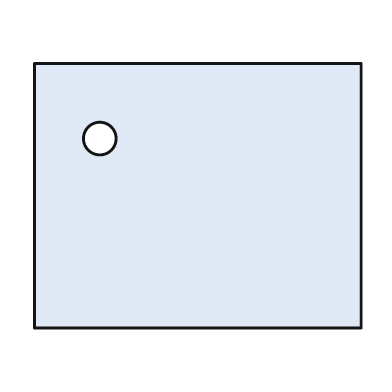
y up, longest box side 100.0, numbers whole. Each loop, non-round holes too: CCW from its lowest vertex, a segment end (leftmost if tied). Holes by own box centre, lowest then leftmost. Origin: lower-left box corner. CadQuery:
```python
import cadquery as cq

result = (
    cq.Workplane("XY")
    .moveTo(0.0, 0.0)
    .lineTo(100.0, 0.0)
    .lineTo(100.0, 81.0)
    .lineTo(0.0, 81.0)
    .close()
    .moveTo(20.0, 58.0)
    .circle(5.0)
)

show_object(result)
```